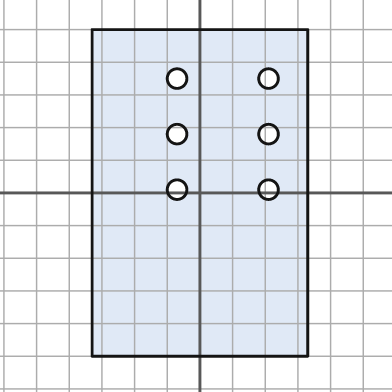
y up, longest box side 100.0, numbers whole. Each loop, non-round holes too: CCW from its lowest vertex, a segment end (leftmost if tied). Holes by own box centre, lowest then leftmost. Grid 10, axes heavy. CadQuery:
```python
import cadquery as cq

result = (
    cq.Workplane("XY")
    .moveTo(-33.0, -50.0)
    .lineTo(33.0, -50.0)
    .lineTo(33.0, 50.0)
    .lineTo(-33.0, 50.0)
    .close()
    .moveTo(-7.0, 1.0)
    .circle(3.0)
    .moveTo(21.0, 1.0)
    .circle(3.0)
    .moveTo(-7.0, 18.0)
    .circle(3.0)
    .moveTo(21.0, 18.0)
    .circle(3.0)
    .moveTo(-7.0, 35.0)
    .circle(3.0)
    .moveTo(21.0, 35.0)
    .circle(3.0)
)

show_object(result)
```